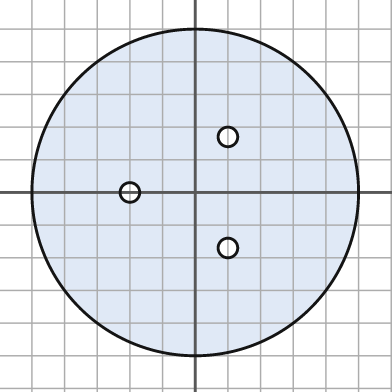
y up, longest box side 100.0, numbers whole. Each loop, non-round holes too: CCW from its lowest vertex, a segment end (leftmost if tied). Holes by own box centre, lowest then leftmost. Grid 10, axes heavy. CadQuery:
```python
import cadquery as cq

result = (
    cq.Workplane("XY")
    .moveTo(0.0, 0.0)
    .circle(50.0)
    .moveTo(10.0, -17.0)
    .circle(3.0)
    .moveTo(-20.0, 0.0)
    .circle(3.0)
    .moveTo(10.0, 17.0)
    .circle(3.0)
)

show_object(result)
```